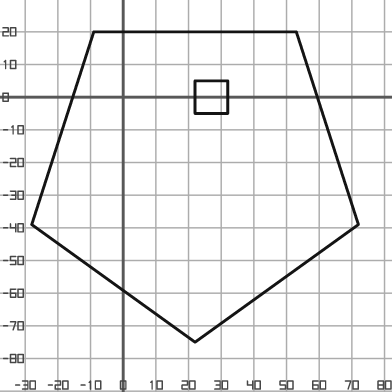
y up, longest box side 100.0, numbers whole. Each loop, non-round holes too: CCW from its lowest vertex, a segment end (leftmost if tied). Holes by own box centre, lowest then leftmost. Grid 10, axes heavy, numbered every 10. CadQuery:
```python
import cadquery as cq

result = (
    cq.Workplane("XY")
    .moveTo(22.0, -75.0)
    .lineTo(72.0, -39.0)
    .lineTo(53.0, 20.0)
    .lineTo(-9.0, 20.0)
    .lineTo(-28.0, -39.0)
    .close()
    .moveTo(22.0, -5.0)
    .lineTo(32.0, -5.0)
    .lineTo(32.0, 5.0)
    .lineTo(22.0, 5.0)
    .close()
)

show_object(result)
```